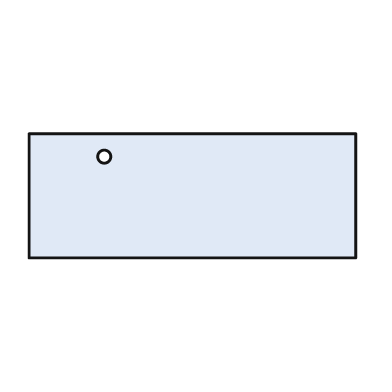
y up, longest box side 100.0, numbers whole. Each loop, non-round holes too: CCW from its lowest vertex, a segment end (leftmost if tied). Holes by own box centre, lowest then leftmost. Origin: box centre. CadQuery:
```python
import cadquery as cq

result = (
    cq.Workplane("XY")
    .moveTo(-50.0, -19.0)
    .lineTo(50.0, -19.0)
    .lineTo(50.0, 19.0)
    .lineTo(-50.0, 19.0)
    .close()
    .moveTo(-27.0, 12.0)
    .circle(2.0)
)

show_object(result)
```